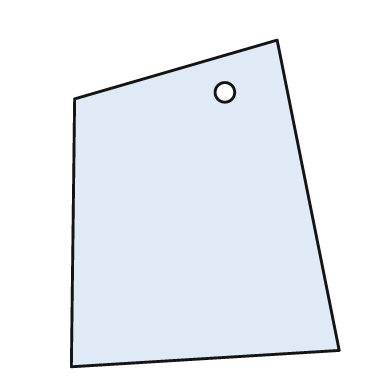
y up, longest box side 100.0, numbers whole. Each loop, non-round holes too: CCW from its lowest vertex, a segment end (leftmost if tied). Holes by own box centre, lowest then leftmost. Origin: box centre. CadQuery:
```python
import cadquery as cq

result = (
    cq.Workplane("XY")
    .moveTo(-41.0, -50.0)
    .lineTo(41.0, -45.0)
    .lineTo(22.0, 50.0)
    .lineTo(-40.0, 32.0)
    .close()
    .moveTo(6.0, 34.0)
    .circle(3.0)
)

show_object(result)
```